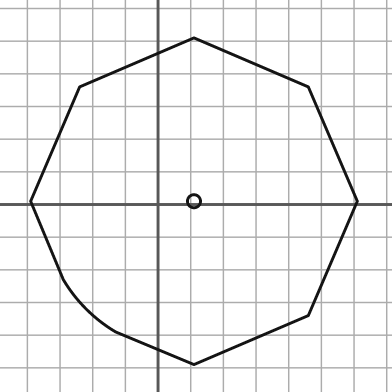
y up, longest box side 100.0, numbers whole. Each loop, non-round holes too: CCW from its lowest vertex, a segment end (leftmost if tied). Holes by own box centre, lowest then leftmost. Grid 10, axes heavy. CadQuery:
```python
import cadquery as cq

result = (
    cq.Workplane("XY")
    .moveTo(11.0, -49.0)
    .lineTo(46.0, -34.0)
    .lineTo(61.0, 1.0)
    .lineTo(46.0, 36.0)
    .lineTo(11.0, 51.0)
    .lineTo(-24.0, 36.0)
    .lineTo(-39.0, 1.0)
    .lineTo(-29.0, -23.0)
    .threePointArc((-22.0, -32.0), (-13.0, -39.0))
    .close()
    .moveTo(11.0, 1.0)
    .circle(2.0)
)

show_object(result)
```